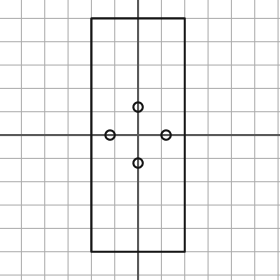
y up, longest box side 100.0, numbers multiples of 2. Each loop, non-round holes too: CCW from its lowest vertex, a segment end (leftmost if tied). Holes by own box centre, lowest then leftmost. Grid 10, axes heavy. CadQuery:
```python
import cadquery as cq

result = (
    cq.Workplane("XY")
    .moveTo(-20.0, -50.0)
    .lineTo(20.0, -50.0)
    .lineTo(20.0, 50.0)
    .lineTo(-20.0, 50.0)
    .close()
    .moveTo(0.0, -12.0)
    .circle(2.0)
    .moveTo(-12.0, 0.0)
    .circle(2.0)
    .moveTo(12.0, 0.0)
    .circle(2.0)
    .moveTo(0.0, 12.0)
    .circle(2.0)
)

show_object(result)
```